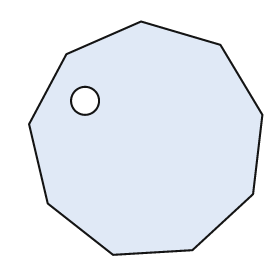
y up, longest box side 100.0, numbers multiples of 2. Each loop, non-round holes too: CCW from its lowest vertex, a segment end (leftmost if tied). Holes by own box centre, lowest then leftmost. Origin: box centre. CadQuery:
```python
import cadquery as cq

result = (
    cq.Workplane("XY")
    .moveTo(-14.0, -50.0)
    .lineTo(20.0, -48.0)
    .lineTo(46.0, -24.0)
    .lineTo(50.0, 10.0)
    .lineTo(32.0, 40.0)
    .lineTo(-2.0, 50.0)
    .lineTo(-34.0, 36.0)
    .lineTo(-50.0, 6.0)
    .lineTo(-42.0, -28.0)
    .close()
    .moveTo(-26.0, 16.0)
    .circle(6.0)
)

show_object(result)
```